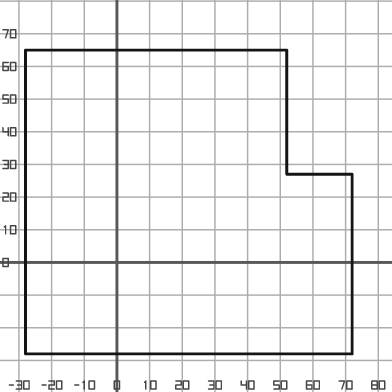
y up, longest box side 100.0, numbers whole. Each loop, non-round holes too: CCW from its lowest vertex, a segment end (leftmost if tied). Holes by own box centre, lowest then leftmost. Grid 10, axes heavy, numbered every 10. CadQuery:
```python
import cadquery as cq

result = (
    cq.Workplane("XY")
    .moveTo(-28.0, -28.0)
    .lineTo(72.0, -28.0)
    .lineTo(72.0, 27.0)
    .lineTo(52.0, 27.0)
    .lineTo(52.0, 65.0)
    .lineTo(-28.0, 65.0)
    .close()
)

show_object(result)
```